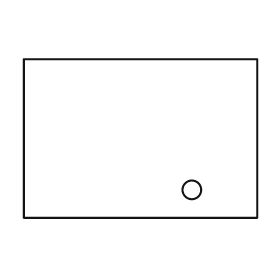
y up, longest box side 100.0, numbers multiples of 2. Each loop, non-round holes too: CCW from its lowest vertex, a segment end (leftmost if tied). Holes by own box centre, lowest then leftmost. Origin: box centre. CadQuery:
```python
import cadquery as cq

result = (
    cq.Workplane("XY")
    .moveTo(-50.0, -34.0)
    .lineTo(50.0, -34.0)
    .lineTo(50.0, 34.0)
    .lineTo(-50.0, 34.0)
    .close()
    .moveTo(22.0, -22.0)
    .circle(4.0)
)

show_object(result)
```